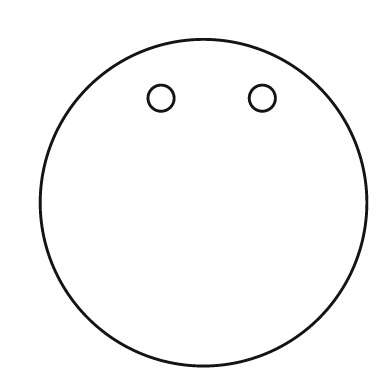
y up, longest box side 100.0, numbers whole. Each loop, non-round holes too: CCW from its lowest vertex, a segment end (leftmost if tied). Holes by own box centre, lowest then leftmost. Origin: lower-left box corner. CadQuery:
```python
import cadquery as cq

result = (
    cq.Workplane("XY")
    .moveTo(50.0, 50.0)
    .circle(50.0)
    .moveTo(37.0, 82.0)
    .circle(4.0)
    .moveTo(68.0, 82.0)
    .circle(4.0)
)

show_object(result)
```